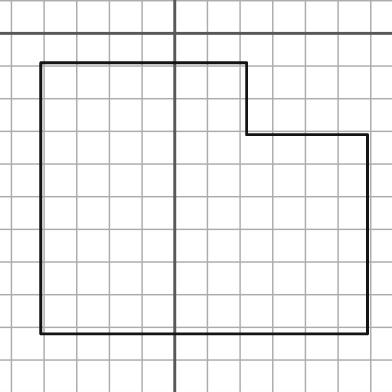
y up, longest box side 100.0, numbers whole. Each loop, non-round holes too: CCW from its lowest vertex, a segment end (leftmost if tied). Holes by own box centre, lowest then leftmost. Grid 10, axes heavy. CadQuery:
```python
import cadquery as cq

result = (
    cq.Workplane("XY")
    .moveTo(-41.0, -92.0)
    .lineTo(59.0, -92.0)
    .lineTo(59.0, -31.0)
    .lineTo(22.0, -31.0)
    .lineTo(22.0, -9.0)
    .lineTo(-41.0, -9.0)
    .close()
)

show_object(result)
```